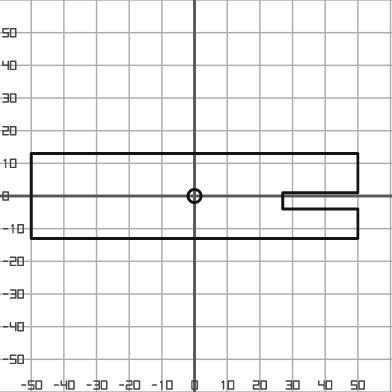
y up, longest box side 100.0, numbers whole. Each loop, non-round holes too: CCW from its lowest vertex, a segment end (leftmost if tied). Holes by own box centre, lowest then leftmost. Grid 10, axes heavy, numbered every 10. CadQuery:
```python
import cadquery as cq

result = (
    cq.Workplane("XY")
    .moveTo(-50.0, -13.0)
    .lineTo(50.0, -13.0)
    .lineTo(50.0, -4.0)
    .lineTo(27.0, -4.0)
    .lineTo(27.0, 1.0)
    .lineTo(50.0, 1.0)
    .lineTo(50.0, 13.0)
    .lineTo(-50.0, 13.0)
    .close()
    .moveTo(0.0, 0.0)
    .circle(2.0)
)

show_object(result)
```